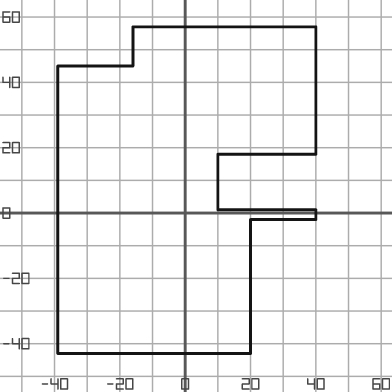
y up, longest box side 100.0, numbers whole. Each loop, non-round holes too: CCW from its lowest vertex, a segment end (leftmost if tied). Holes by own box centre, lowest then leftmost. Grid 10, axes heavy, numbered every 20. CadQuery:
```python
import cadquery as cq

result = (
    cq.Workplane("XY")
    .moveTo(-39.0, -43.0)
    .lineTo(20.0, -43.0)
    .lineTo(20.0, -2.0)
    .lineTo(40.0, -2.0)
    .lineTo(40.0, 1.0)
    .lineTo(10.0, 1.0)
    .lineTo(10.0, 18.0)
    .lineTo(40.0, 18.0)
    .lineTo(40.0, 57.0)
    .lineTo(-16.0, 57.0)
    .lineTo(-16.0, 45.0)
    .lineTo(-39.0, 45.0)
    .close()
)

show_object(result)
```